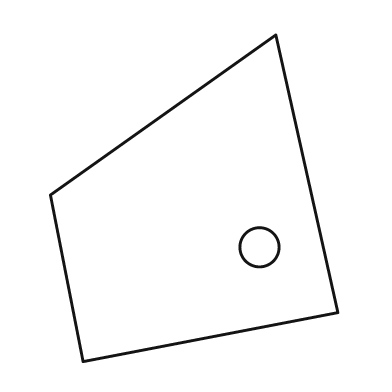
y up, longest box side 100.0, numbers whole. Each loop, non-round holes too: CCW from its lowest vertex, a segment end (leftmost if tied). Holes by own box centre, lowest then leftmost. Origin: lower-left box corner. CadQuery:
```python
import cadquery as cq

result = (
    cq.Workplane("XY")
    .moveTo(10.0, 0.0)
    .lineTo(88.0, 15.0)
    .lineTo(69.0, 100.0)
    .lineTo(0.0, 51.0)
    .close()
    .moveTo(64.0, 35.0)
    .circle(6.0)
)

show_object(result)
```